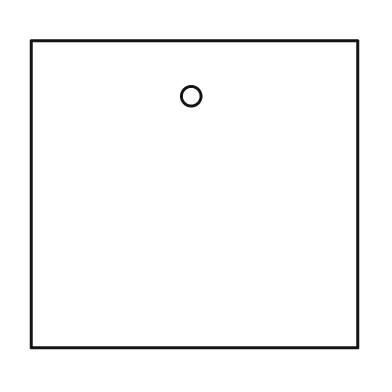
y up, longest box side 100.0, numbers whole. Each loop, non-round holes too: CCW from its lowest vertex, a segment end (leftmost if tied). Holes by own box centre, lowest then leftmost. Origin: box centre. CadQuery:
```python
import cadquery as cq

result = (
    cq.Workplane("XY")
    .moveTo(-50.0, -47.0)
    .lineTo(50.0, -47.0)
    .lineTo(50.0, 47.0)
    .lineTo(-50.0, 47.0)
    .close()
    .moveTo(-1.0, 30.0)
    .circle(3.0)
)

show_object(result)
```